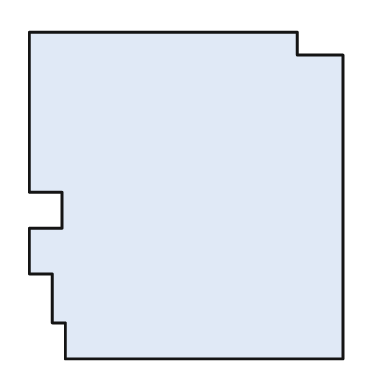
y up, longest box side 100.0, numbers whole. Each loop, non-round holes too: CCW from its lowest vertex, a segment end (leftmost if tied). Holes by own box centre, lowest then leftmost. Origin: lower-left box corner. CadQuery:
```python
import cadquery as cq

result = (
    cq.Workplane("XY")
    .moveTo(11.0, 0.0)
    .lineTo(96.0, 0.0)
    .lineTo(96.0, 93.0)
    .lineTo(82.0, 93.0)
    .lineTo(82.0, 100.0)
    .lineTo(0.0, 100.0)
    .lineTo(0.0, 51.0)
    .lineTo(10.0, 51.0)
    .lineTo(10.0, 40.0)
    .lineTo(0.0, 40.0)
    .lineTo(0.0, 26.0)
    .lineTo(7.0, 26.0)
    .lineTo(7.0, 11.0)
    .lineTo(11.0, 11.0)
    .close()
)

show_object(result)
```